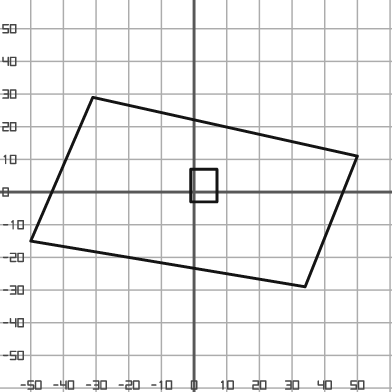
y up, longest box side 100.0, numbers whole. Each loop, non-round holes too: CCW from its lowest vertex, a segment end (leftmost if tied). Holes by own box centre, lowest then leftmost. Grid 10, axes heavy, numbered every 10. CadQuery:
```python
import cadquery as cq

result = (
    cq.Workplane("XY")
    .moveTo(34.0, -29.0)
    .lineTo(50.0, 11.0)
    .lineTo(-31.0, 29.0)
    .lineTo(-50.0, -15.0)
    .close()
    .moveTo(-1.0, -3.0)
    .lineTo(7.0, -3.0)
    .lineTo(7.0, 7.0)
    .lineTo(-1.0, 7.0)
    .close()
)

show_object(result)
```